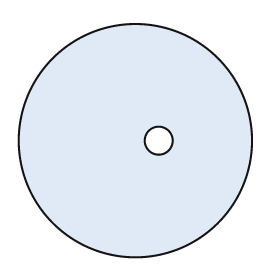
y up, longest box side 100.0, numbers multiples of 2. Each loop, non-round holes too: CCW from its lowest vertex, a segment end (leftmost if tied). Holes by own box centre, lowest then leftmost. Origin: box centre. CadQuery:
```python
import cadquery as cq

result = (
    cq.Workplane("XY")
    .moveTo(0.0, 0.0)
    .circle(50.0)
    .moveTo(10.0, 0.0)
    .circle(6.0)
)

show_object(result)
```